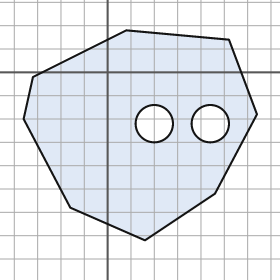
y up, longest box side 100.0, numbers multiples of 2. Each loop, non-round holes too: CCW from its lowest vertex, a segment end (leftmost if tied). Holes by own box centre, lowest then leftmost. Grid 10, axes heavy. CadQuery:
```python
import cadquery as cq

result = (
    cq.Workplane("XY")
    .moveTo(16.0, -72.0)
    .lineTo(46.0, -52.0)
    .lineTo(64.0, -18.0)
    .lineTo(52.0, 14.0)
    .lineTo(8.0, 18.0)
    .lineTo(-32.0, -2.0)
    .lineTo(-36.0, -20.0)
    .lineTo(-16.0, -58.0)
    .close()
    .moveTo(20.0, -22.0)
    .circle(8.0)
    .moveTo(44.0, -22.0)
    .circle(8.0)
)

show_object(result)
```